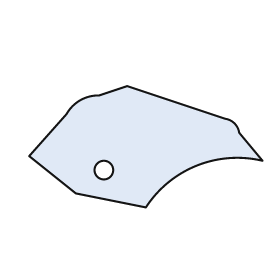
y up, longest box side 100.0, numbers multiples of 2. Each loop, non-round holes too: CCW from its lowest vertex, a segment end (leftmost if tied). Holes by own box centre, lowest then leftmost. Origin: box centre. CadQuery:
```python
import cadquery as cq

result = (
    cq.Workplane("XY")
    .moveTo(0.0, -26.0)
    .threePointArc((22.0, -8.0), (50.0, -6.0))
    .lineTo(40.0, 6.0)
    .threePointArc((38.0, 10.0), (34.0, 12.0))
    .lineTo(-8.0, 26.0)
    .lineTo(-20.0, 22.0)
    .threePointArc((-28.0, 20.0), (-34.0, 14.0))
    .lineTo(-50.0, -4.0)
    .lineTo(-30.0, -20.0)
    .close()
    .moveTo(-18.0, -10.0)
    .circle(4.0)
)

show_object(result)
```